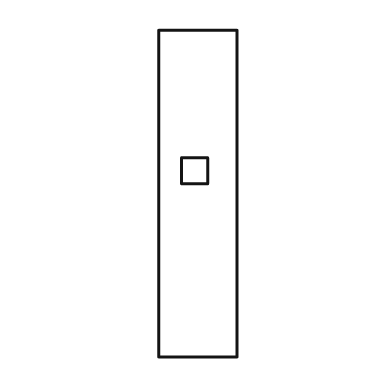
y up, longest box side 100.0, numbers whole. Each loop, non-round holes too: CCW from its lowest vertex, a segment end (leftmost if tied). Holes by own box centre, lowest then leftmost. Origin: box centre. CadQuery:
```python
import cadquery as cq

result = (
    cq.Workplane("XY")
    .moveTo(-12.0, -50.0)
    .lineTo(12.0, -50.0)
    .lineTo(12.0, 50.0)
    .lineTo(-12.0, 50.0)
    .close()
    .moveTo(-5.0, 3.0)
    .lineTo(3.0, 3.0)
    .lineTo(3.0, 11.0)
    .lineTo(-5.0, 11.0)
    .close()
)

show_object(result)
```